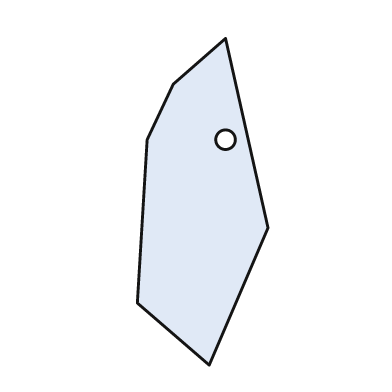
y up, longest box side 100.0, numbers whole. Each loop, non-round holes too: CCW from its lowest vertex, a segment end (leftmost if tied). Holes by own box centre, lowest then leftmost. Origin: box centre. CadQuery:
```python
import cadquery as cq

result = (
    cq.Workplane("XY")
    .moveTo(2.0, -50.0)
    .lineTo(20.0, -8.0)
    .lineTo(7.0, 50.0)
    .lineTo(-9.0, 36.0)
    .lineTo(-17.0, 19.0)
    .lineTo(-20.0, -31.0)
    .close()
    .moveTo(7.0, 19.0)
    .circle(3.0)
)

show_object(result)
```